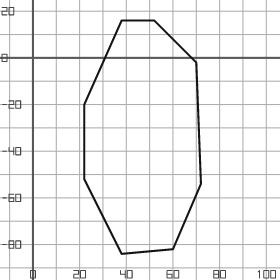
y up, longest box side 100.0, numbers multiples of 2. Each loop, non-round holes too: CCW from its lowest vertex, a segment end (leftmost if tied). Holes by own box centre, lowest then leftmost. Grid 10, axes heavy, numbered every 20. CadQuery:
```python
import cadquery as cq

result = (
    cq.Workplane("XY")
    .moveTo(38.0, -84.0)
    .lineTo(60.0, -82.0)
    .lineTo(72.0, -54.0)
    .lineTo(70.0, -2.0)
    .lineTo(52.0, 16.0)
    .lineTo(38.0, 16.0)
    .lineTo(22.0, -20.0)
    .lineTo(22.0, -52.0)
    .close()
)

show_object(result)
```